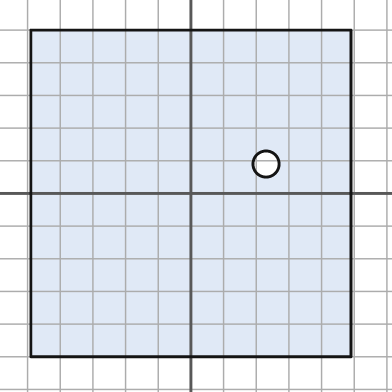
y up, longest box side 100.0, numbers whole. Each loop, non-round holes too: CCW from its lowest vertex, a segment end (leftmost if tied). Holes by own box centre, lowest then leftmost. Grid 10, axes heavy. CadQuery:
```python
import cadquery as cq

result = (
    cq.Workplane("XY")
    .moveTo(-49.0, -50.0)
    .lineTo(49.0, -50.0)
    .lineTo(49.0, 50.0)
    .lineTo(-49.0, 50.0)
    .close()
    .moveTo(23.0, 9.0)
    .circle(4.0)
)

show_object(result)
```